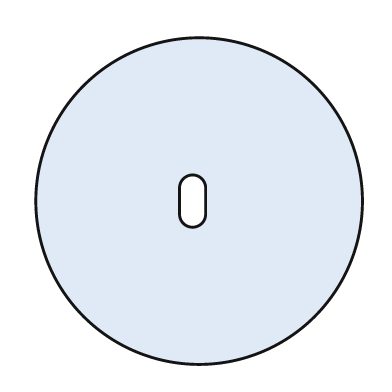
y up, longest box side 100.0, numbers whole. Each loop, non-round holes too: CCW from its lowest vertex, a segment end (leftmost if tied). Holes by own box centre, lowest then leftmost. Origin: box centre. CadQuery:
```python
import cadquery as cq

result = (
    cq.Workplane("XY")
    .moveTo(0.0, 0.0)
    .circle(50.0)
    .moveTo(-6.0, -4.0)
    .threePointArc((-2.0, -8.0), (2.0, -4.0))
    .lineTo(2.0, 4.0)
    .threePointArc((-2.0, 8.0), (-6.0, 4.0))
    .close()
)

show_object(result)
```